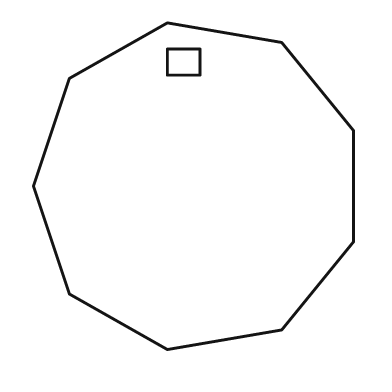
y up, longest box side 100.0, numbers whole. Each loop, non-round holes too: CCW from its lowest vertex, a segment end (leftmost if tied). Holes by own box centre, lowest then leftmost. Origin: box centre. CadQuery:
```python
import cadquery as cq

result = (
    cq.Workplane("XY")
    .moveTo(-8.0, -50.0)
    .lineTo(27.0, -44.0)
    .lineTo(49.0, -17.0)
    .lineTo(49.0, 17.0)
    .lineTo(27.0, 44.0)
    .lineTo(-8.0, 50.0)
    .lineTo(-38.0, 33.0)
    .lineTo(-49.0, 0.0)
    .lineTo(-38.0, -33.0)
    .close()
    .moveTo(-8.0, 34.0)
    .lineTo(2.0, 34.0)
    .lineTo(2.0, 42.0)
    .lineTo(-8.0, 42.0)
    .close()
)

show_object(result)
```